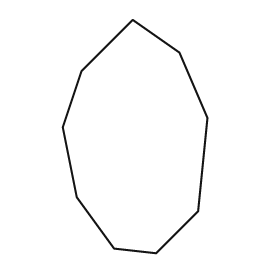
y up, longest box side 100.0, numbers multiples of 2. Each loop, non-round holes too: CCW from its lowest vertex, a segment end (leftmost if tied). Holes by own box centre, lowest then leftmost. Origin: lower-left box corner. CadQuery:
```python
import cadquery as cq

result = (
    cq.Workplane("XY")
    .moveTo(40.0, 0.0)
    .lineTo(58.0, 18.0)
    .lineTo(62.0, 58.0)
    .lineTo(50.0, 86.0)
    .lineTo(30.0, 100.0)
    .lineTo(8.0, 78.0)
    .lineTo(0.0, 54.0)
    .lineTo(6.0, 24.0)
    .lineTo(22.0, 2.0)
    .close()
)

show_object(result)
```